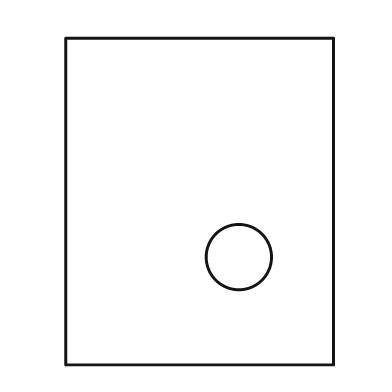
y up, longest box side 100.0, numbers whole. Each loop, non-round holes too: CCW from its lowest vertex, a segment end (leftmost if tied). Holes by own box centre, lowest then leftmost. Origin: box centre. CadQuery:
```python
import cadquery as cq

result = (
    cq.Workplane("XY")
    .moveTo(-41.0, -50.0)
    .lineTo(41.0, -50.0)
    .lineTo(41.0, 50.0)
    .lineTo(-41.0, 50.0)
    .close()
    .moveTo(12.0, -17.0)
    .circle(10.0)
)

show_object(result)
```